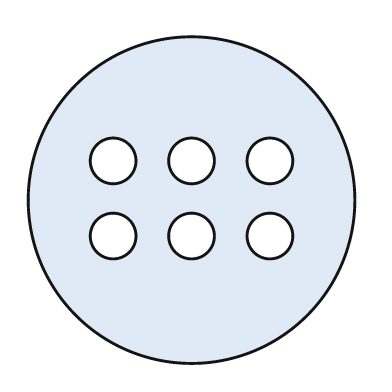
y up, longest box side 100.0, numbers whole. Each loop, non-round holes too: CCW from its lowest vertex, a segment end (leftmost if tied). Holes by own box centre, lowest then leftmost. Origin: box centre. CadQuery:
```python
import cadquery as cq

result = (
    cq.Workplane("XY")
    .moveTo(0.0, 0.0)
    .circle(50.0)
    .moveTo(-24.0, -11.0)
    .circle(7.0)
    .moveTo(0.0, -11.0)
    .circle(7.0)
    .moveTo(24.0, -11.0)
    .circle(7.0)
    .moveTo(-24.0, 12.0)
    .circle(7.0)
    .moveTo(0.0, 12.0)
    .circle(7.0)
    .moveTo(24.0, 12.0)
    .circle(7.0)
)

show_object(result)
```